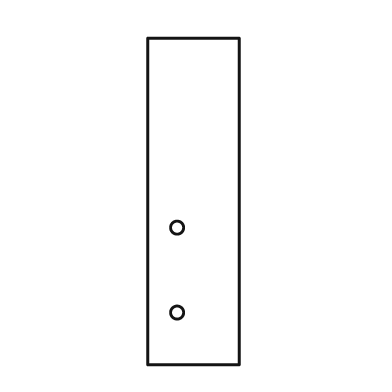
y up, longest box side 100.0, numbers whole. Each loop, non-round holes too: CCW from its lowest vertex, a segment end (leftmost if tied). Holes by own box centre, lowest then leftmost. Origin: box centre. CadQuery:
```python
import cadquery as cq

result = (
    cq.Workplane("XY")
    .moveTo(-14.0, -50.0)
    .lineTo(14.0, -50.0)
    .lineTo(14.0, 50.0)
    .lineTo(-14.0, 50.0)
    .close()
    .moveTo(-5.0, -34.0)
    .circle(2.0)
    .moveTo(-5.0, -8.0)
    .circle(2.0)
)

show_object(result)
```